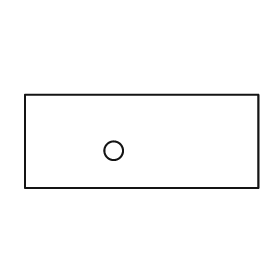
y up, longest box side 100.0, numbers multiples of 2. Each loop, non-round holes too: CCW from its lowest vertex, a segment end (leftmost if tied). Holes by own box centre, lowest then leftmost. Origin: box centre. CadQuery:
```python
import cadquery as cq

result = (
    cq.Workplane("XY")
    .moveTo(-50.0, -20.0)
    .lineTo(50.0, -20.0)
    .lineTo(50.0, 20.0)
    .lineTo(-50.0, 20.0)
    .close()
    .moveTo(-12.0, -4.0)
    .circle(4.0)
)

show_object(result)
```